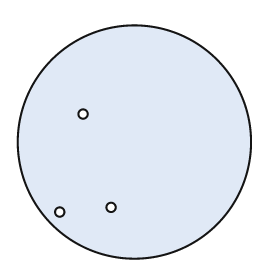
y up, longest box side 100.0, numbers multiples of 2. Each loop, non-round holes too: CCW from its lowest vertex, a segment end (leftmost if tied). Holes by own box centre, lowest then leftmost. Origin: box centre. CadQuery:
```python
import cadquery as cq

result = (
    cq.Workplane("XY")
    .moveTo(0.0, 0.0)
    .circle(50.0)
    .moveTo(-32.0, -30.0)
    .circle(2.0)
    .moveTo(-10.0, -28.0)
    .circle(2.0)
    .moveTo(-22.0, 12.0)
    .circle(2.0)
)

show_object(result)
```